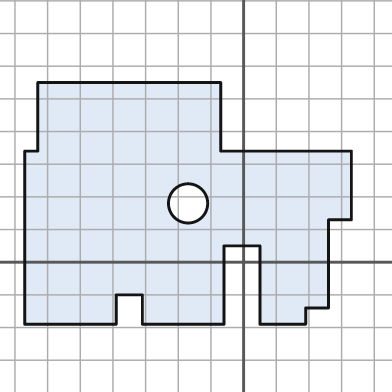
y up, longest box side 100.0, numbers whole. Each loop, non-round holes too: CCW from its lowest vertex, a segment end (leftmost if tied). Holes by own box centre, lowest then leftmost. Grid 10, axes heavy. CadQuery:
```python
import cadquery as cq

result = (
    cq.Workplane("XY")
    .moveTo(-67.0, -19.0)
    .lineTo(-39.0, -19.0)
    .lineTo(-39.0, -10.0)
    .lineTo(-31.0, -10.0)
    .lineTo(-31.0, -19.0)
    .lineTo(-6.0, -19.0)
    .lineTo(-6.0, 5.0)
    .lineTo(5.0, 5.0)
    .lineTo(5.0, -19.0)
    .lineTo(19.0, -19.0)
    .lineTo(19.0, -14.0)
    .lineTo(26.0, -14.0)
    .lineTo(26.0, 13.0)
    .lineTo(33.0, 13.0)
    .lineTo(33.0, 34.0)
    .lineTo(-7.0, 34.0)
    .lineTo(-7.0, 55.0)
    .lineTo(-63.0, 55.0)
    .lineTo(-63.0, 34.0)
    .lineTo(-67.0, 34.0)
    .close()
    .moveTo(-17.0, 18.0)
    .circle(6.0)
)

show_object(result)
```